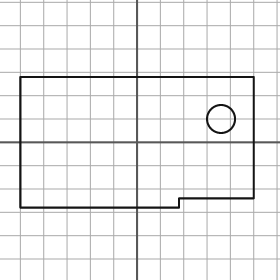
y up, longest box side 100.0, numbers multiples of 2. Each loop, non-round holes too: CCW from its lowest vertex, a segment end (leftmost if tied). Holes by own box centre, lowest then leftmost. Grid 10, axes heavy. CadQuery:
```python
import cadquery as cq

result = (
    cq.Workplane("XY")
    .moveTo(-50.0, -28.0)
    .lineTo(18.0, -28.0)
    .lineTo(18.0, -24.0)
    .lineTo(50.0, -24.0)
    .lineTo(50.0, 28.0)
    .lineTo(-50.0, 28.0)
    .close()
    .moveTo(36.0, 10.0)
    .circle(6.0)
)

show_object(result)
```